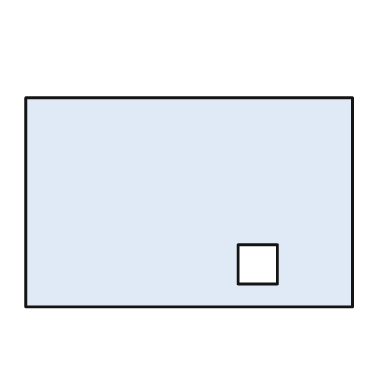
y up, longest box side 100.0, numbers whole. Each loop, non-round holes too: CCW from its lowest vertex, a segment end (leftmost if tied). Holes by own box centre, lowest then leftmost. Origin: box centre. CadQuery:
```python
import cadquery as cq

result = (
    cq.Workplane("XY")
    .moveTo(-50.0, -32.0)
    .lineTo(50.0, -32.0)
    .lineTo(50.0, 32.0)
    .lineTo(-50.0, 32.0)
    .close()
    .moveTo(15.0, -25.0)
    .lineTo(27.0, -25.0)
    .lineTo(27.0, -13.0)
    .lineTo(15.0, -13.0)
    .close()
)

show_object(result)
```